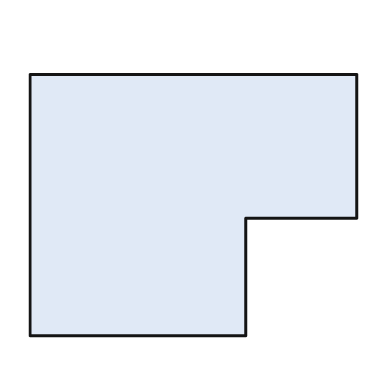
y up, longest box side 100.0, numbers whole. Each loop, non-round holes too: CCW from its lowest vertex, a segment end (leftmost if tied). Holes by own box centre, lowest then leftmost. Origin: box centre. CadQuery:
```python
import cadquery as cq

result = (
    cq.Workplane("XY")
    .moveTo(-50.0, -40.0)
    .lineTo(16.0, -40.0)
    .lineTo(16.0, -4.0)
    .lineTo(50.0, -4.0)
    .lineTo(50.0, 40.0)
    .lineTo(-50.0, 40.0)
    .close()
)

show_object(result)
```